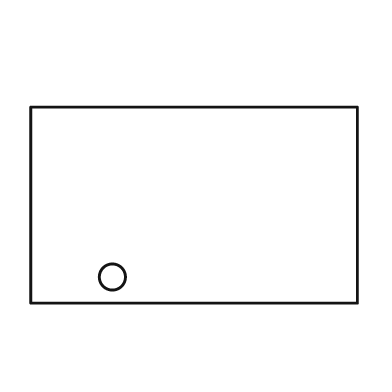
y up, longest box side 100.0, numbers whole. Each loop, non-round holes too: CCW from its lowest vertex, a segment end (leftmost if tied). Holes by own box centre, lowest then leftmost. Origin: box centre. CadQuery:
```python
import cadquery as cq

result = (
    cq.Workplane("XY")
    .moveTo(-50.0, -30.0)
    .lineTo(50.0, -30.0)
    .lineTo(50.0, 30.0)
    .lineTo(-50.0, 30.0)
    .close()
    .moveTo(-25.0, -22.0)
    .circle(4.0)
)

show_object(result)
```